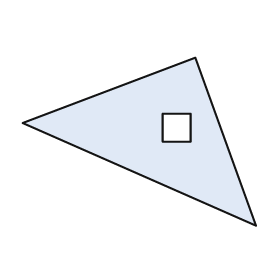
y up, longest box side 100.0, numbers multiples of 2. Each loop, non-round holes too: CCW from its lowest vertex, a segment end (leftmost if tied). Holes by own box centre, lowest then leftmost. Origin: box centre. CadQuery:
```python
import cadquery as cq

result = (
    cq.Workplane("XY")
    .moveTo(50.0, -36.0)
    .lineTo(24.0, 36.0)
    .lineTo(-50.0, 8.0)
    .close()
    .moveTo(10.0, 0.0)
    .lineTo(22.0, 0.0)
    .lineTo(22.0, 12.0)
    .lineTo(10.0, 12.0)
    .close()
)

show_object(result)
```